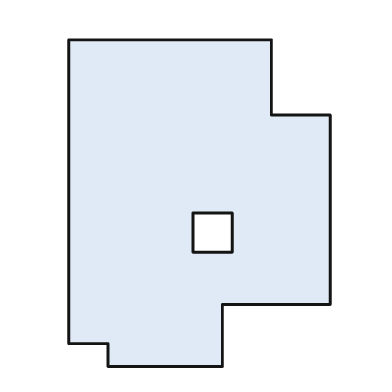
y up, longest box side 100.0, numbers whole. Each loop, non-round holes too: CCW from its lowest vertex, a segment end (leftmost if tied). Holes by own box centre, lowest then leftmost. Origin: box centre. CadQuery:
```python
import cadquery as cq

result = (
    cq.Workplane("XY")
    .moveTo(-28.0, -50.0)
    .lineTo(7.0, -50.0)
    .lineTo(7.0, -31.0)
    .lineTo(40.0, -31.0)
    .lineTo(40.0, 27.0)
    .lineTo(22.0, 27.0)
    .lineTo(22.0, 50.0)
    .lineTo(-40.0, 50.0)
    .lineTo(-40.0, -43.0)
    .lineTo(-28.0, -43.0)
    .close()
    .moveTo(-2.0, -15.0)
    .lineTo(10.0, -15.0)
    .lineTo(10.0, -3.0)
    .lineTo(-2.0, -3.0)
    .close()
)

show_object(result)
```